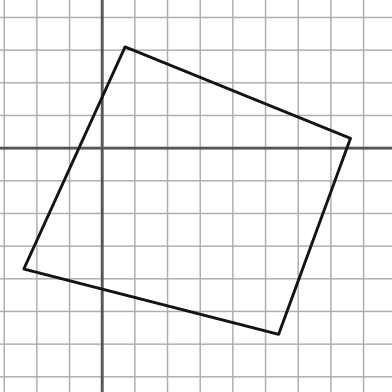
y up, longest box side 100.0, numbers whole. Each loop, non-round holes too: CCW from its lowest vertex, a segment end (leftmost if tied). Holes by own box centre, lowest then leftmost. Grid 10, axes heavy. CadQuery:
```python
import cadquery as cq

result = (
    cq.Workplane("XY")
    .moveTo(54.0, -57.0)
    .lineTo(76.0, 3.0)
    .lineTo(7.0, 31.0)
    .lineTo(-24.0, -37.0)
    .close()
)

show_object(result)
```